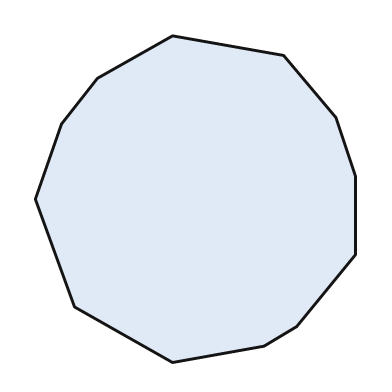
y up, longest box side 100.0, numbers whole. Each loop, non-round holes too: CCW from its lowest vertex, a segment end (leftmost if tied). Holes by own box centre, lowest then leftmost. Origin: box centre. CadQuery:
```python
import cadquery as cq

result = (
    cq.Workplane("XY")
    .moveTo(-7.0, -50.0)
    .lineTo(21.0, -45.0)
    .lineTo(31.0, -39.0)
    .lineTo(49.0, -17.0)
    .lineTo(49.0, 7.0)
    .lineTo(43.0, 25.0)
    .lineTo(27.0, 44.0)
    .lineTo(-7.0, 50.0)
    .lineTo(-30.0, 37.0)
    .lineTo(-41.0, 23.0)
    .lineTo(-49.0, 0.0)
    .lineTo(-37.0, -33.0)
    .close()
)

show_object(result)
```